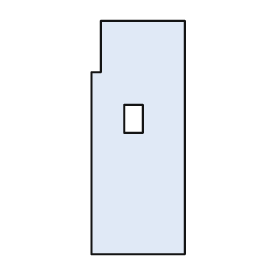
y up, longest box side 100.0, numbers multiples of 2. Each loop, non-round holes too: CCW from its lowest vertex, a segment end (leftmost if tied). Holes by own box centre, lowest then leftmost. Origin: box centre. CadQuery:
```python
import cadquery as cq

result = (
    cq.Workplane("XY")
    .moveTo(-20.0, -50.0)
    .lineTo(20.0, -50.0)
    .lineTo(20.0, 50.0)
    .lineTo(-16.0, 50.0)
    .lineTo(-16.0, 28.0)
    .lineTo(-20.0, 28.0)
    .close()
    .moveTo(-6.0, 2.0)
    .lineTo(2.0, 2.0)
    .lineTo(2.0, 14.0)
    .lineTo(-6.0, 14.0)
    .close()
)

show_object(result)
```